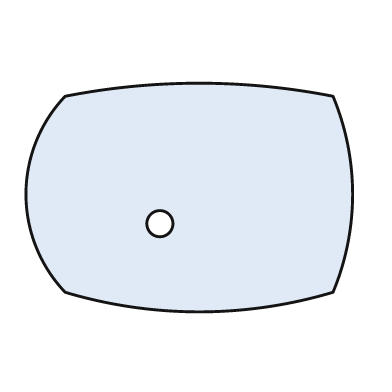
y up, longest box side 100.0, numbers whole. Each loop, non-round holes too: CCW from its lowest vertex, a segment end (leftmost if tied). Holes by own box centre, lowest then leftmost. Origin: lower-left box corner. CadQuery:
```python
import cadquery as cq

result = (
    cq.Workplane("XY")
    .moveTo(12.0, 6.0)
    .threePointArc((53.0, 0.0), (94.0, 6.0))
    .threePointArc((100.0, 36.0), (94.0, 66.0))
    .threePointArc((53.0, 70.0), (12.0, 66.0))
    .threePointArc((0.0, 36.0), (12.0, 6.0))
    .close()
    .moveTo(41.0, 27.0)
    .circle(4.0)
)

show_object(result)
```